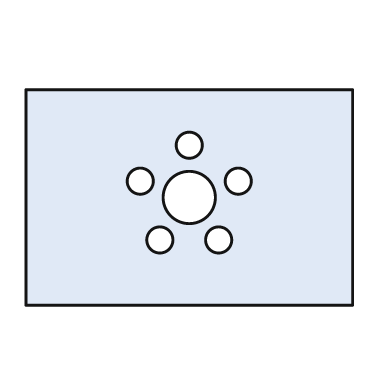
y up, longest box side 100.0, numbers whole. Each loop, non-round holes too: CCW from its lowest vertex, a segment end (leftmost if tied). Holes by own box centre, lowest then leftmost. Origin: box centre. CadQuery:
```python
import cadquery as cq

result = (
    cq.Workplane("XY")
    .moveTo(-50.0, -33.0)
    .lineTo(50.0, -33.0)
    .lineTo(50.0, 33.0)
    .lineTo(-50.0, 33.0)
    .close()
    .moveTo(-9.0, -13.0)
    .circle(4.0)
    .moveTo(9.0, -13.0)
    .circle(4.0)
    .moveTo(0.0, 0.0)
    .circle(8.0)
    .moveTo(-15.0, 5.0)
    .circle(4.0)
    .moveTo(15.0, 5.0)
    .circle(4.0)
    .moveTo(0.0, 16.0)
    .circle(4.0)
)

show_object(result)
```